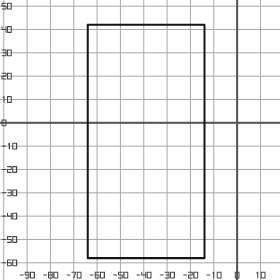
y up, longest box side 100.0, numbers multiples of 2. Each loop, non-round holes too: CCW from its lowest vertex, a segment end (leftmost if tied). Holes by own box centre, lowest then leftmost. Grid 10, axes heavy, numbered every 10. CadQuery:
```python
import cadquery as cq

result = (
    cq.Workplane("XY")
    .moveTo(-64.0, -58.0)
    .lineTo(-14.0, -58.0)
    .lineTo(-14.0, 42.0)
    .lineTo(-64.0, 42.0)
    .close()
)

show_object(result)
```